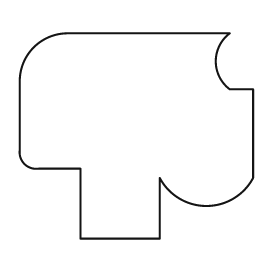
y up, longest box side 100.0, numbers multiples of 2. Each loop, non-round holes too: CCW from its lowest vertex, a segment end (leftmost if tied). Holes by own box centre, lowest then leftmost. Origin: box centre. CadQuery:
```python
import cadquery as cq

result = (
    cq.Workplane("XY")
    .moveTo(-24.0, -44.0)
    .lineTo(10.0, -44.0)
    .lineTo(10.0, -18.0)
    .threePointArc((30.0, -30.0), (50.0, -18.0))
    .lineTo(50.0, 20.0)
    .lineTo(40.0, 20.0)
    .threePointArc((34.0, 32.0), (40.0, 44.0))
    .lineTo(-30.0, 44.0)
    .threePointArc((-44.0, 38.0), (-50.0, 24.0))
    .lineTo(-50.0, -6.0)
    .threePointArc((-48.0, -12.0), (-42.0, -14.0))
    .lineTo(-24.0, -14.0)
    .close()
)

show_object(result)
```